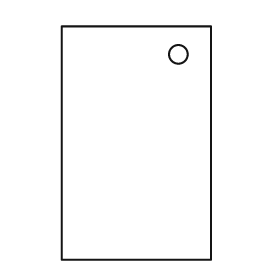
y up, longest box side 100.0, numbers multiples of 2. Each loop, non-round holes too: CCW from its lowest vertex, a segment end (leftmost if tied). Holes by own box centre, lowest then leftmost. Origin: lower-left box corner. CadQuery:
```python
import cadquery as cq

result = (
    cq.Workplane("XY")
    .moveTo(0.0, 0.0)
    .lineTo(64.0, 0.0)
    .lineTo(64.0, 100.0)
    .lineTo(0.0, 100.0)
    .close()
    .moveTo(50.0, 88.0)
    .circle(4.0)
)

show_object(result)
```